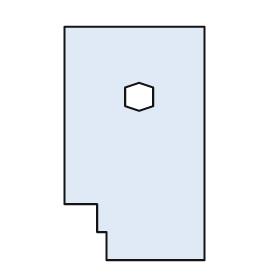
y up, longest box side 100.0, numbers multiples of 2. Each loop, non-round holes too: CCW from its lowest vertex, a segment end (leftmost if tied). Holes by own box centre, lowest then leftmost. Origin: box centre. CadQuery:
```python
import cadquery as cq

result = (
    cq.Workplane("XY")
    .moveTo(-12.0, -50.0)
    .lineTo(30.0, -50.0)
    .lineTo(30.0, 50.0)
    .lineTo(-30.0, 50.0)
    .lineTo(-30.0, -26.0)
    .lineTo(-16.0, -26.0)
    .lineTo(-16.0, -38.0)
    .lineTo(-12.0, -38.0)
    .close()
    .moveTo(2.0, 14.0)
    .lineTo(8.0, 16.0)
    .lineTo(8.0, 24.0)
    .lineTo(2.0, 26.0)
    .lineTo(-4.0, 24.0)
    .lineTo(-4.0, 16.0)
    .close()
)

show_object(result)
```